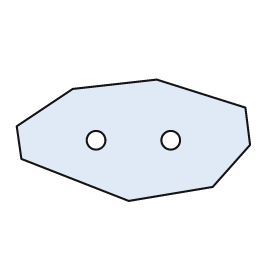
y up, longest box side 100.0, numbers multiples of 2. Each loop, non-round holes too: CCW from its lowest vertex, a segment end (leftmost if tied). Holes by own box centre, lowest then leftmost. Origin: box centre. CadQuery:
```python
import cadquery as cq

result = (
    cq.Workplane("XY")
    .moveTo(-2.0, -26.0)
    .lineTo(34.0, -20.0)
    .lineTo(50.0, -2.0)
    .lineTo(48.0, 14.0)
    .lineTo(10.0, 26.0)
    .lineTo(-26.0, 22.0)
    .lineTo(-50.0, 6.0)
    .lineTo(-48.0, -8.0)
    .close()
    .moveTo(-16.0, 0.0)
    .circle(4.0)
    .moveTo(16.0, 0.0)
    .circle(4.0)
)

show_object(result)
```